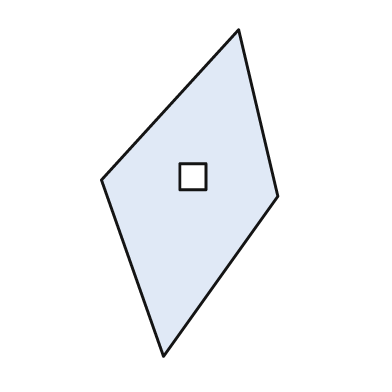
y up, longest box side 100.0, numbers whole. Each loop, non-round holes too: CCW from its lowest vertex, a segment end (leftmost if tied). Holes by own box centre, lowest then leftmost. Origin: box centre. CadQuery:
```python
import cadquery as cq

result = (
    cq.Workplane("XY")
    .moveTo(-8.0, -50.0)
    .lineTo(27.0, -1.0)
    .lineTo(15.0, 50.0)
    .lineTo(-27.0, 4.0)
    .close()
    .moveTo(-3.0, 1.0)
    .lineTo(5.0, 1.0)
    .lineTo(5.0, 9.0)
    .lineTo(-3.0, 9.0)
    .close()
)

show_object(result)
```